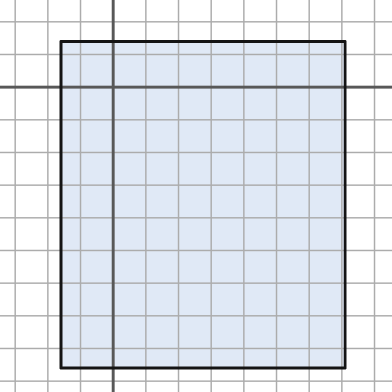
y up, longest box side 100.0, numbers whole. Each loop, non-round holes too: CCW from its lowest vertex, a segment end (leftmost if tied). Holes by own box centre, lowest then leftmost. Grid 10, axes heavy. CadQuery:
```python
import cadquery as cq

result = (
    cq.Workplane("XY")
    .moveTo(-16.0, -86.0)
    .lineTo(71.0, -86.0)
    .lineTo(71.0, 14.0)
    .lineTo(-16.0, 14.0)
    .close()
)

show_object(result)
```